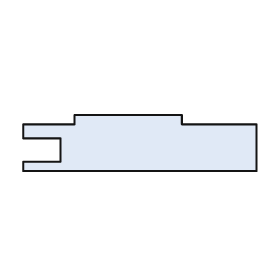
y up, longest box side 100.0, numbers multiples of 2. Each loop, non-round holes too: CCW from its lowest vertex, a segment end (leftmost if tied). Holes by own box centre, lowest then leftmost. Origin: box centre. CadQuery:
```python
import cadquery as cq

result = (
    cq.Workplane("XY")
    .moveTo(-50.0, -12.0)
    .lineTo(50.0, -12.0)
    .lineTo(50.0, 8.0)
    .lineTo(18.0, 8.0)
    .lineTo(18.0, 12.0)
    .lineTo(-28.0, 12.0)
    .lineTo(-28.0, 8.0)
    .lineTo(-50.0, 8.0)
    .lineTo(-50.0, 2.0)
    .lineTo(-34.0, 2.0)
    .lineTo(-34.0, -8.0)
    .lineTo(-50.0, -8.0)
    .close()
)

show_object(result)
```